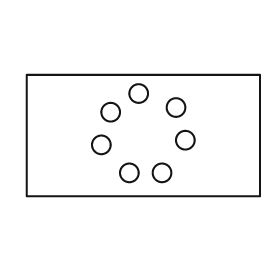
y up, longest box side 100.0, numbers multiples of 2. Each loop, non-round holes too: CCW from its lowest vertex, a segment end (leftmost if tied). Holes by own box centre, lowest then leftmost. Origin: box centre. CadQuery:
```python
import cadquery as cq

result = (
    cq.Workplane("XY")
    .moveTo(-50.0, -26.0)
    .lineTo(50.0, -26.0)
    .lineTo(50.0, 26.0)
    .lineTo(-50.0, 26.0)
    .close()
    .moveTo(-6.0, -16.0)
    .circle(4.0)
    .moveTo(8.0, -16.0)
    .circle(4.0)
    .moveTo(-18.0, -4.0)
    .circle(4.0)
    .moveTo(18.0, -2.0)
    .circle(4.0)
    .moveTo(-14.0, 10.0)
    .circle(4.0)
    .moveTo(14.0, 12.0)
    .circle(4.0)
    .moveTo(-2.0, 18.0)
    .circle(4.0)
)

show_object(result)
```